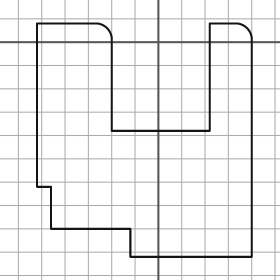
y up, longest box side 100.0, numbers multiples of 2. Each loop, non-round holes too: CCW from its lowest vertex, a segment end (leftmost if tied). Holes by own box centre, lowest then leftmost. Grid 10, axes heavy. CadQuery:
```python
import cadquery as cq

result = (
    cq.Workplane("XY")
    .moveTo(-12.0, -92.0)
    .lineTo(40.0, -92.0)
    .lineTo(40.0, 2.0)
    .threePointArc((38.0, 6.0), (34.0, 8.0))
    .lineTo(22.0, 8.0)
    .lineTo(22.0, -38.0)
    .lineTo(-20.0, -38.0)
    .lineTo(-20.0, 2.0)
    .threePointArc((-22.0, 6.0), (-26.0, 8.0))
    .lineTo(-52.0, 8.0)
    .lineTo(-52.0, -62.0)
    .lineTo(-46.0, -62.0)
    .lineTo(-46.0, -80.0)
    .lineTo(-12.0, -80.0)
    .close()
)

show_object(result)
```